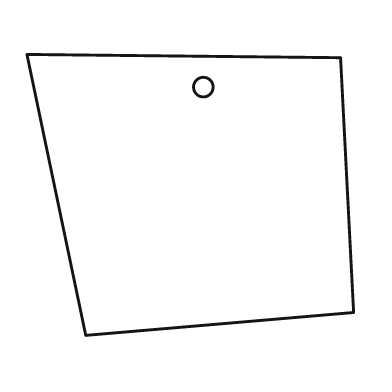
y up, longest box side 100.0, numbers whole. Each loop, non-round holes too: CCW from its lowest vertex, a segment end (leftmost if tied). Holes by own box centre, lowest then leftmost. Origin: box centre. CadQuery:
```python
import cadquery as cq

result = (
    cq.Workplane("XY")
    .moveTo(-32.0, -43.0)
    .lineTo(50.0, -36.0)
    .lineTo(46.0, 42.0)
    .lineTo(-50.0, 43.0)
    .close()
    .moveTo(4.0, 33.0)
    .circle(3.0)
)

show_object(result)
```